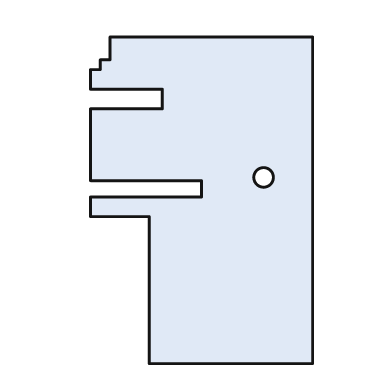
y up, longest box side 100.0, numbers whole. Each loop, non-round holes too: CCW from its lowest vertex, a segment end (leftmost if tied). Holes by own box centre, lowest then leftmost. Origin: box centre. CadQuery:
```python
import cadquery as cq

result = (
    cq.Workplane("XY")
    .moveTo(-16.0, -50.0)
    .lineTo(34.0, -50.0)
    .lineTo(34.0, 50.0)
    .lineTo(-28.0, 50.0)
    .lineTo(-28.0, 43.0)
    .lineTo(-31.0, 43.0)
    .lineTo(-31.0, 40.0)
    .lineTo(-34.0, 40.0)
    .lineTo(-34.0, 34.0)
    .lineTo(-12.0, 34.0)
    .lineTo(-12.0, 28.0)
    .lineTo(-34.0, 28.0)
    .lineTo(-34.0, 6.0)
    .lineTo(0.0, 6.0)
    .lineTo(0.0, 1.0)
    .lineTo(-34.0, 1.0)
    .lineTo(-34.0, -5.0)
    .lineTo(-16.0, -5.0)
    .close()
    .moveTo(19.0, 7.0)
    .circle(3.0)
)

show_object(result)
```